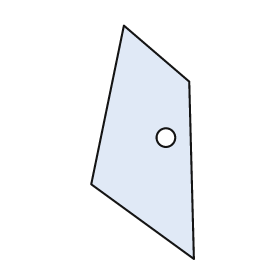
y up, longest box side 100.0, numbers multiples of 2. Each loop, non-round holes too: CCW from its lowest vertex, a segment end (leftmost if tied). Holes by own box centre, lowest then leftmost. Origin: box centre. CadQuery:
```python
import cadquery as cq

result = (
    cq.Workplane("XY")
    .moveTo(22.0, -50.0)
    .lineTo(20.0, 26.0)
    .lineTo(-8.0, 50.0)
    .lineTo(-22.0, -18.0)
    .close()
    .moveTo(10.0, 2.0)
    .circle(4.0)
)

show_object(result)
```